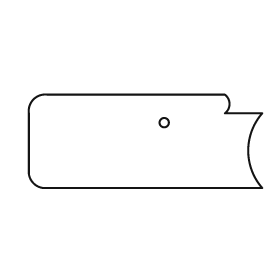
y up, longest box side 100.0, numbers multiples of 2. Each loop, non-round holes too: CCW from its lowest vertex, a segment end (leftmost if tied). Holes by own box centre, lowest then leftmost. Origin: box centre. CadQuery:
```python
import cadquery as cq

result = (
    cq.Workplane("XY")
    .moveTo(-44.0, -20.0)
    .lineTo(50.0, -20.0)
    .threePointArc((44.0, -4.0), (50.0, 12.0))
    .lineTo(34.0, 12.0)
    .threePointArc((36.0, 16.0), (34.0, 20.0))
    .lineTo(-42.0, 20.0)
    .threePointArc((-48.0, 18.0), (-50.0, 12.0))
    .lineTo(-50.0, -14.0)
    .threePointArc((-48.0, -18.0), (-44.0, -20.0))
    .close()
    .moveTo(8.0, 8.0)
    .circle(2.0)
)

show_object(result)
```